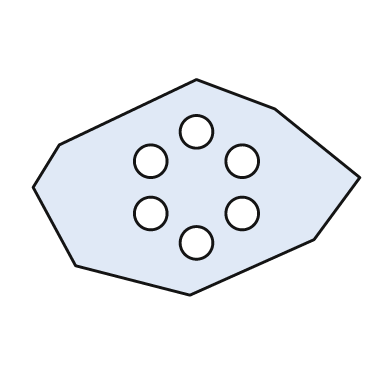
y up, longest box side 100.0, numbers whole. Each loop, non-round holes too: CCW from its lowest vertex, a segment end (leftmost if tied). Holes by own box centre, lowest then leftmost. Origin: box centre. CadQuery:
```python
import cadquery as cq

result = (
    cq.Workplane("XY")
    .moveTo(-2.0, -33.0)
    .lineTo(36.0, -16.0)
    .lineTo(50.0, 3.0)
    .lineTo(24.0, 24.0)
    .lineTo(0.0, 33.0)
    .lineTo(-42.0, 13.0)
    .lineTo(-50.0, 0.0)
    .lineTo(-37.0, -24.0)
    .close()
    .moveTo(0.0, -17.0)
    .circle(5.0)
    .moveTo(-14.0, -8.0)
    .circle(5.0)
    .moveTo(14.0, -8.0)
    .circle(5.0)
    .moveTo(-14.0, 8.0)
    .circle(5.0)
    .moveTo(14.0, 8.0)
    .circle(5.0)
    .moveTo(0.0, 17.0)
    .circle(5.0)
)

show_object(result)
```